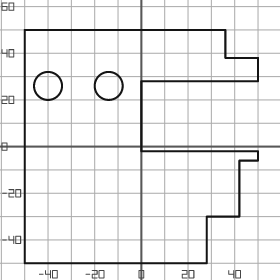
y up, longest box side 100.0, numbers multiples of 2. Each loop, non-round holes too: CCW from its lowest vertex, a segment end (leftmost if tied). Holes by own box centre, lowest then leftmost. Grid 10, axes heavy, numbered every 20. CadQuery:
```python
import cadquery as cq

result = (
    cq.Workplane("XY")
    .moveTo(-50.0, -50.0)
    .lineTo(28.0, -50.0)
    .lineTo(28.0, -30.0)
    .lineTo(42.0, -30.0)
    .lineTo(42.0, -6.0)
    .lineTo(50.0, -6.0)
    .lineTo(50.0, -2.0)
    .lineTo(0.0, -2.0)
    .lineTo(0.0, 28.0)
    .lineTo(50.0, 28.0)
    .lineTo(50.0, 38.0)
    .lineTo(36.0, 38.0)
    .lineTo(36.0, 50.0)
    .lineTo(-50.0, 50.0)
    .close()
    .moveTo(-40.0, 26.0)
    .circle(6.0)
    .moveTo(-14.0, 26.0)
    .circle(6.0)
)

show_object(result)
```